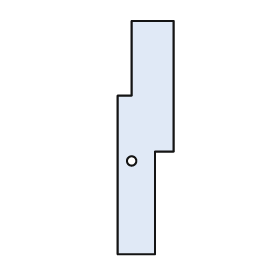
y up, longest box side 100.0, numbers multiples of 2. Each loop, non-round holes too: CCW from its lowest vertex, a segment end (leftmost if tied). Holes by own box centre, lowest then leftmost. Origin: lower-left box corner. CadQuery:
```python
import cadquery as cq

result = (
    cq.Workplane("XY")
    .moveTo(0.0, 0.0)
    .lineTo(16.0, 0.0)
    .lineTo(16.0, 44.0)
    .lineTo(24.0, 44.0)
    .lineTo(24.0, 100.0)
    .lineTo(6.0, 100.0)
    .lineTo(6.0, 68.0)
    .lineTo(0.0, 68.0)
    .close()
    .moveTo(6.0, 40.0)
    .circle(2.0)
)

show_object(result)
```